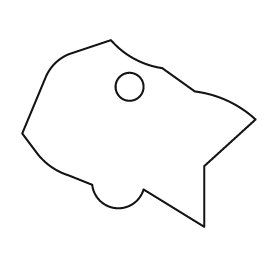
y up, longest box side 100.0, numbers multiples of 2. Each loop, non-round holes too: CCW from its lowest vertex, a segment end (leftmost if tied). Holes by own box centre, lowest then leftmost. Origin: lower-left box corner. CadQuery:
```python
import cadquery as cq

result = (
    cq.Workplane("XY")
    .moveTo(78.0, 0.0)
    .lineTo(78.0, 26.0)
    .lineTo(100.0, 46.0)
    .threePointArc((88.0, 54.0), (74.0, 58.0))
    .lineTo(60.0, 68.0)
    .threePointArc((48.0, 72.0), (38.0, 80.0))
    .lineTo(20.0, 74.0)
    .threePointArc((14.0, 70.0), (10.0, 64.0))
    .lineTo(0.0, 40.0)
    .lineTo(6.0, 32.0)
    .threePointArc((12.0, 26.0), (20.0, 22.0))
    .lineTo(30.0, 18.0)
    .threePointArc((40.0, 8.0), (52.0, 16.0))
    .close()
    .moveTo(46.0, 60.0)
    .circle(6.0)
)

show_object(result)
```